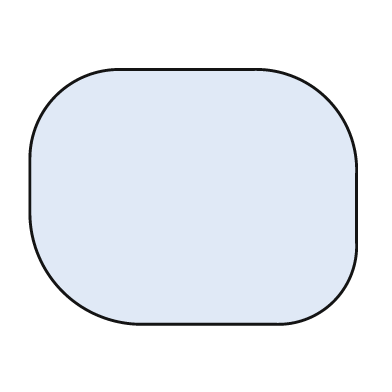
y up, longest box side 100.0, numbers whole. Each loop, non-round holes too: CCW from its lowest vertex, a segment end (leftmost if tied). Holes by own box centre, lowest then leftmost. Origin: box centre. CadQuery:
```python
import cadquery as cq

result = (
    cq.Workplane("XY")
    .moveTo(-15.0, -39.0)
    .lineTo(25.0, -39.0)
    .threePointArc((43.0, -32.0), (50.0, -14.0))
    .lineTo(50.0, 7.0)
    .threePointArc((41.0, 30.0), (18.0, 39.0))
    .lineTo(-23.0, 39.0)
    .threePointArc((-42.0, 31.0), (-50.0, 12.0))
    .lineTo(-50.0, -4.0)
    .threePointArc((-40.0, -29.0), (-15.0, -39.0))
    .close()
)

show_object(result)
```